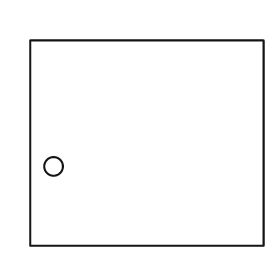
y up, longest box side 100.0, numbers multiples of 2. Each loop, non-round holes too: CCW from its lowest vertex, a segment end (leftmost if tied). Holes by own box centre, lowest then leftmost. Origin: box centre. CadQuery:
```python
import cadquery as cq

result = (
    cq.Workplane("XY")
    .moveTo(-50.0, -44.0)
    .lineTo(50.0, -44.0)
    .lineTo(50.0, 44.0)
    .lineTo(-50.0, 44.0)
    .close()
    .moveTo(-40.0, -10.0)
    .circle(4.0)
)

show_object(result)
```